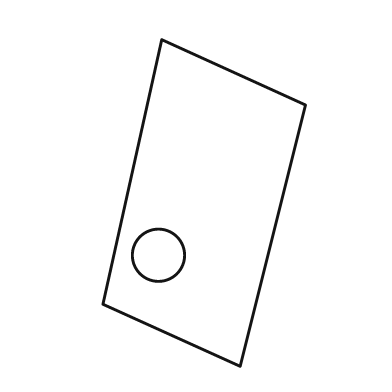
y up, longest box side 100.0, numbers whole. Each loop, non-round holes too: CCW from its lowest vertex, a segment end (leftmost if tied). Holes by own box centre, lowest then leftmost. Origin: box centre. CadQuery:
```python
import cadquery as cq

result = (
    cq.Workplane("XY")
    .moveTo(11.0, -50.0)
    .lineTo(31.0, 30.0)
    .lineTo(-13.0, 50.0)
    .lineTo(-31.0, -31.0)
    .close()
    .moveTo(-14.0, -16.0)
    .circle(8.0)
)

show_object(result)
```